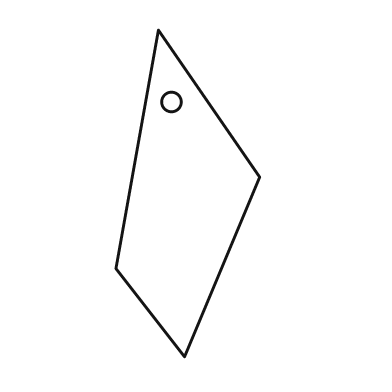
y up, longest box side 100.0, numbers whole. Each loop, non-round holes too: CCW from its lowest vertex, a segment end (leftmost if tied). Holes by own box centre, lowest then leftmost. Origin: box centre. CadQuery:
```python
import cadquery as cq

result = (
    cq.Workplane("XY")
    .moveTo(-1.0, -50.0)
    .lineTo(22.0, 5.0)
    .lineTo(-9.0, 50.0)
    .lineTo(-22.0, -23.0)
    .close()
    .moveTo(-5.0, 28.0)
    .circle(3.0)
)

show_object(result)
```